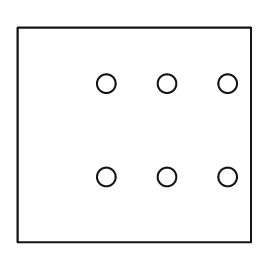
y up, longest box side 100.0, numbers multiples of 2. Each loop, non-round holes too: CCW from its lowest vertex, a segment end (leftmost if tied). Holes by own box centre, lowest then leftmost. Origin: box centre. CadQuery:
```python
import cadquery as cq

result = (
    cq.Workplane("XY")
    .moveTo(-50.0, -46.0)
    .lineTo(50.0, -46.0)
    .lineTo(50.0, 46.0)
    .lineTo(-50.0, 46.0)
    .close()
    .moveTo(-12.0, -18.0)
    .circle(4.0)
    .moveTo(14.0, -18.0)
    .circle(4.0)
    .moveTo(40.0, -18.0)
    .circle(4.0)
    .moveTo(-12.0, 22.0)
    .circle(4.0)
    .moveTo(14.0, 22.0)
    .circle(4.0)
    .moveTo(40.0, 22.0)
    .circle(4.0)
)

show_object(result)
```